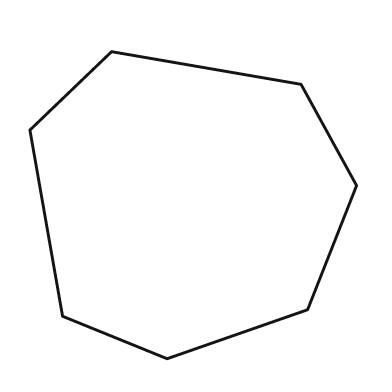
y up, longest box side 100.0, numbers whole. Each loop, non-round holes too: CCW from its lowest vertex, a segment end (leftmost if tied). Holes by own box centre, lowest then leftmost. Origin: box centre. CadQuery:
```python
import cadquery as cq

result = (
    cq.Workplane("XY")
    .moveTo(-8.0, -47.0)
    .lineTo(35.0, -32.0)
    .lineTo(50.0, 6.0)
    .lineTo(33.0, 37.0)
    .lineTo(-25.0, 47.0)
    .lineTo(-50.0, 23.0)
    .lineTo(-40.0, -34.0)
    .close()
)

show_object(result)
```